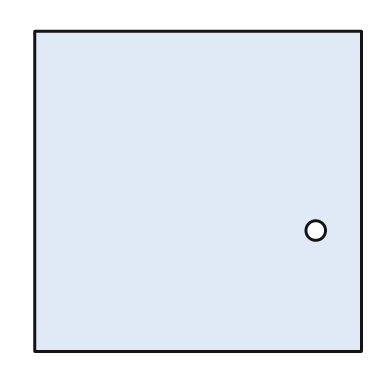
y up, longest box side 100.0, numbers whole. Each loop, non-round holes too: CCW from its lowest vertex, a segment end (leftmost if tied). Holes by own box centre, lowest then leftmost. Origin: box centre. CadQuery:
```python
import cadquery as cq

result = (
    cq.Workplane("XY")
    .moveTo(-50.0, -49.0)
    .lineTo(50.0, -49.0)
    .lineTo(50.0, 49.0)
    .lineTo(-50.0, 49.0)
    .close()
    .moveTo(36.0, -12.0)
    .circle(3.0)
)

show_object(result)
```